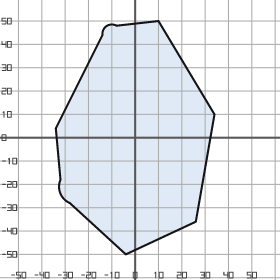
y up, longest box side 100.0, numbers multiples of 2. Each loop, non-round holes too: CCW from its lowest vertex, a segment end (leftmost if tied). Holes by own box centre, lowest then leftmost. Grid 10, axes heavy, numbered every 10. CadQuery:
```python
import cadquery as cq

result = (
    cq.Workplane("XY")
    .moveTo(-4.0, -50.0)
    .lineTo(26.0, -36.0)
    .lineTo(34.0, 10.0)
    .lineTo(10.0, 50.0)
    .lineTo(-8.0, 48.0)
    .threePointArc((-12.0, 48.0), (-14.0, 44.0))
    .lineTo(-34.0, 4.0)
    .lineTo(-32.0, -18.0)
    .threePointArc((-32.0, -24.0), (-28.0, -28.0))
    .close()
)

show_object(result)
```